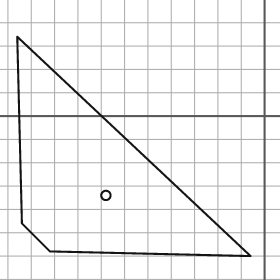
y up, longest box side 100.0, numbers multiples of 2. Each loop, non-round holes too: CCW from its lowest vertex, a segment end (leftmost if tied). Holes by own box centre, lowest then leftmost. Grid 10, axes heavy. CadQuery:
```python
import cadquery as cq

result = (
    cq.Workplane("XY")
    .moveTo(-6.0, -60.0)
    .lineTo(-106.0, 34.0)
    .lineTo(-104.0, -46.0)
    .lineTo(-92.0, -58.0)
    .close()
    .moveTo(-68.0, -34.0)
    .circle(2.0)
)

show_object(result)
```